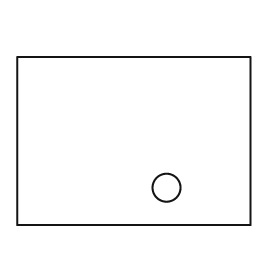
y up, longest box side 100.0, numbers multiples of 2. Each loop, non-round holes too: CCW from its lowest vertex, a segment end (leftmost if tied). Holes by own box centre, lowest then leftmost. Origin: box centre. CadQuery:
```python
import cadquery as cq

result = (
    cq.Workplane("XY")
    .moveTo(-50.0, -36.0)
    .lineTo(50.0, -36.0)
    .lineTo(50.0, 36.0)
    .lineTo(-50.0, 36.0)
    .close()
    .moveTo(14.0, -20.0)
    .circle(6.0)
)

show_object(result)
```